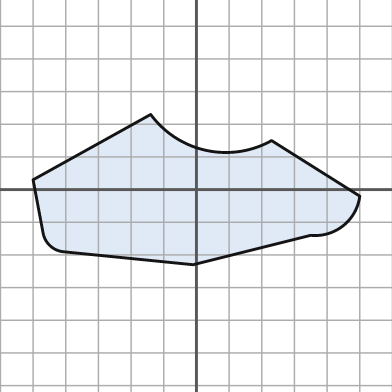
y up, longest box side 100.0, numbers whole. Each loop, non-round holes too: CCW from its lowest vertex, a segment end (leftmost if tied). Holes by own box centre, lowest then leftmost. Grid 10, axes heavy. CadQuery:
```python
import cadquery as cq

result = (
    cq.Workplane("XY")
    .moveTo(-1.0, -23.0)
    .lineTo(35.0, -14.0)
    .threePointArc((45.0, -11.0), (50.0, -2.0))
    .lineTo(23.0, 15.0)
    .threePointArc((3.0, 12.0), (-14.0, 23.0))
    .lineTo(-50.0, 3.0)
    .lineTo(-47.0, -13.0)
    .threePointArc((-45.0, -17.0), (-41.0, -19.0))
    .close()
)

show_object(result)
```